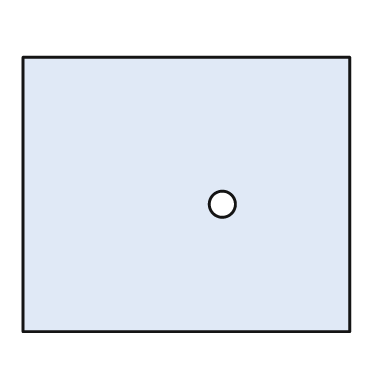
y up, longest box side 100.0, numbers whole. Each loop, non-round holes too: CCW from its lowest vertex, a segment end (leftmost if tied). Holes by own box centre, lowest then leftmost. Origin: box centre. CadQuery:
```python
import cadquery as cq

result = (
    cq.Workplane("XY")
    .moveTo(-50.0, -42.0)
    .lineTo(50.0, -42.0)
    .lineTo(50.0, 42.0)
    .lineTo(-50.0, 42.0)
    .close()
    .moveTo(11.0, -3.0)
    .circle(4.0)
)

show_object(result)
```